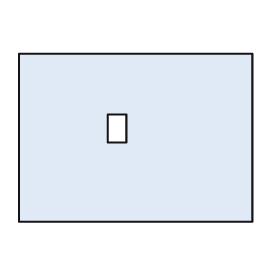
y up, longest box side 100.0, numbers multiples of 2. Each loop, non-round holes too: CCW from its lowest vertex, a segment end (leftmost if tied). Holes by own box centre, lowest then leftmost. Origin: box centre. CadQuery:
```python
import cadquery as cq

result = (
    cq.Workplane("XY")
    .moveTo(-50.0, -36.0)
    .lineTo(50.0, -36.0)
    .lineTo(50.0, 36.0)
    .lineTo(-50.0, 36.0)
    .close()
    .moveTo(-12.0, -2.0)
    .lineTo(-4.0, -2.0)
    .lineTo(-4.0, 10.0)
    .lineTo(-12.0, 10.0)
    .close()
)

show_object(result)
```